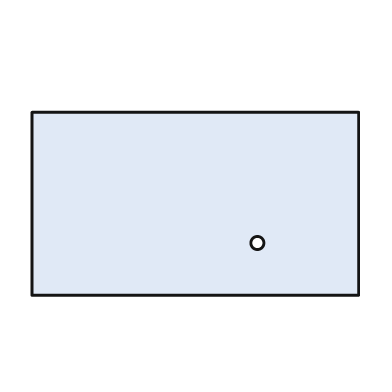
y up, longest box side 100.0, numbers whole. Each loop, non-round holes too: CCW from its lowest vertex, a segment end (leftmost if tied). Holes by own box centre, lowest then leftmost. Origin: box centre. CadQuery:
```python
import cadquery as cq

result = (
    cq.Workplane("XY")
    .moveTo(-50.0, -28.0)
    .lineTo(50.0, -28.0)
    .lineTo(50.0, 28.0)
    .lineTo(-50.0, 28.0)
    .close()
    .moveTo(19.0, -12.0)
    .circle(2.0)
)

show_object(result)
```